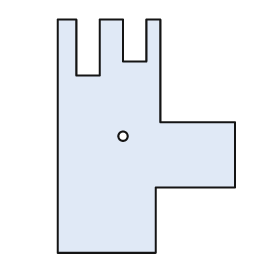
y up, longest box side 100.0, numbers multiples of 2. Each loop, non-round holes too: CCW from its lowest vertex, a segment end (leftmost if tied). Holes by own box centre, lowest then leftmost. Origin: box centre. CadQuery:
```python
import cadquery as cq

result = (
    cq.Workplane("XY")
    .moveTo(-38.0, -50.0)
    .lineTo(4.0, -50.0)
    .lineTo(4.0, -22.0)
    .lineTo(38.0, -22.0)
    .lineTo(38.0, 6.0)
    .lineTo(6.0, 6.0)
    .lineTo(6.0, 50.0)
    .lineTo(0.0, 50.0)
    .lineTo(0.0, 32.0)
    .lineTo(-10.0, 32.0)
    .lineTo(-10.0, 50.0)
    .lineTo(-20.0, 50.0)
    .lineTo(-20.0, 26.0)
    .lineTo(-30.0, 26.0)
    .lineTo(-30.0, 50.0)
    .lineTo(-38.0, 50.0)
    .close()
    .moveTo(-10.0, 0.0)
    .circle(2.0)
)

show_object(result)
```